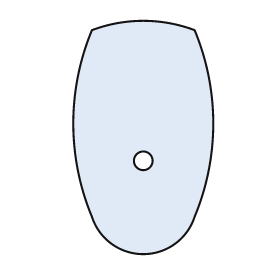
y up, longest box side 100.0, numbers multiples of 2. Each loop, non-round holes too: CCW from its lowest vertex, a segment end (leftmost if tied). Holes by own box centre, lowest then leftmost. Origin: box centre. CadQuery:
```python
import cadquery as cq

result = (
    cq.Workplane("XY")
    .moveTo(-22.0, -34.0)
    .threePointArc((0.0, -50.0), (22.0, -34.0))
    .threePointArc((30.0, 6.0), (22.0, 46.0))
    .threePointArc((0.0, 50.0), (-22.0, 46.0))
    .threePointArc((-30.0, 6.0), (-22.0, -34.0))
    .close()
    .moveTo(0.0, -10.0)
    .circle(4.0)
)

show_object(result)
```